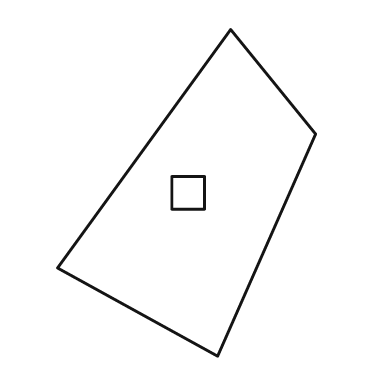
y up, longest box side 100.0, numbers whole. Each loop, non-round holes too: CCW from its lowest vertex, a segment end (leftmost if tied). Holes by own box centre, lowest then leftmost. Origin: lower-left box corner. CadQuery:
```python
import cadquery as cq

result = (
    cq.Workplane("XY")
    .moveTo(49.0, 0.0)
    .lineTo(79.0, 68.0)
    .lineTo(53.0, 100.0)
    .lineTo(0.0, 27.0)
    .close()
    .moveTo(35.0, 45.0)
    .lineTo(45.0, 45.0)
    .lineTo(45.0, 55.0)
    .lineTo(35.0, 55.0)
    .close()
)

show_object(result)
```